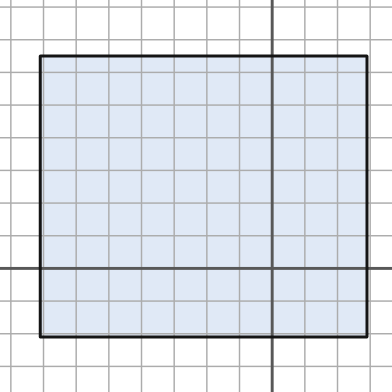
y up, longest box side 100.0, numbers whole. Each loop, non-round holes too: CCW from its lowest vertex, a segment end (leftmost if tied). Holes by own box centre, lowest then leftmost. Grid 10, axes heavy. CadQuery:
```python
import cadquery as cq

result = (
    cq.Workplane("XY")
    .moveTo(-71.0, -21.0)
    .lineTo(29.0, -21.0)
    .lineTo(29.0, 65.0)
    .lineTo(-71.0, 65.0)
    .close()
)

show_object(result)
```